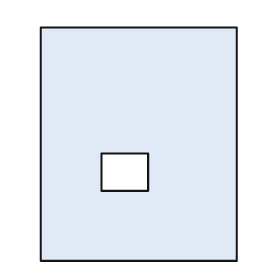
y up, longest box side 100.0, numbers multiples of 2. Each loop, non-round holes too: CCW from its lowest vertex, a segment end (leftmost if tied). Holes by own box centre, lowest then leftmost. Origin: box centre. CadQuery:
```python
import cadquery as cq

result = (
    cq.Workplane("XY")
    .moveTo(-42.0, -50.0)
    .lineTo(42.0, -50.0)
    .lineTo(42.0, 50.0)
    .lineTo(-42.0, 50.0)
    .close()
    .moveTo(-16.0, -20.0)
    .lineTo(4.0, -20.0)
    .lineTo(4.0, -4.0)
    .lineTo(-16.0, -4.0)
    .close()
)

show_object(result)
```